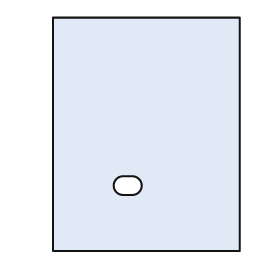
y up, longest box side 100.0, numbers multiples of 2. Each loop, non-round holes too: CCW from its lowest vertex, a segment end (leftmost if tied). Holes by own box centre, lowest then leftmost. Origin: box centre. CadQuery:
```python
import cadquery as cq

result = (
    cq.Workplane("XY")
    .moveTo(-40.0, -50.0)
    .lineTo(40.0, -50.0)
    .lineTo(40.0, 50.0)
    .lineTo(-40.0, 50.0)
    .close()
    .moveTo(-10.0, -26.0)
    .lineTo(-6.0, -26.0)
    .threePointArc((-2.0, -22.0), (-6.0, -18.0))
    .lineTo(-10.0, -18.0)
    .threePointArc((-14.0, -22.0), (-10.0, -26.0))
    .close()
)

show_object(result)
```